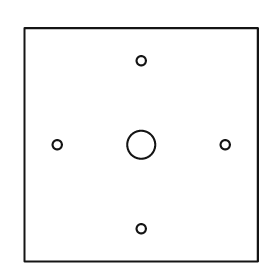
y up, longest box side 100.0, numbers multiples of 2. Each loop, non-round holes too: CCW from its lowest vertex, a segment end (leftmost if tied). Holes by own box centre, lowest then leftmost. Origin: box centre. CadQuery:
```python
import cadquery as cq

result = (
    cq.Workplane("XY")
    .moveTo(-50.0, -50.0)
    .lineTo(50.0, -50.0)
    .lineTo(50.0, 50.0)
    .lineTo(-50.0, 50.0)
    .close()
    .moveTo(0.0, -36.0)
    .circle(2.0)
    .moveTo(-36.0, 0.0)
    .circle(2.0)
    .moveTo(0.0, 0.0)
    .circle(6.0)
    .moveTo(36.0, 0.0)
    .circle(2.0)
    .moveTo(0.0, 36.0)
    .circle(2.0)
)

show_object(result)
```